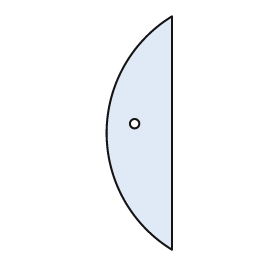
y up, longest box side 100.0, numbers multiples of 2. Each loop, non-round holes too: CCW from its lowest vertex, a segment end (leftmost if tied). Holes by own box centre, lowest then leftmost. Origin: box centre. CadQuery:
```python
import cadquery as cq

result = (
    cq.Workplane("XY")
    .moveTo(14.0, -50.0)
    .lineTo(14.0, 50.0)
    .threePointArc((-14.0, 0.0), (14.0, -50.0))
    .close()
    .moveTo(-2.0, 4.0)
    .circle(2.0)
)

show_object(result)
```